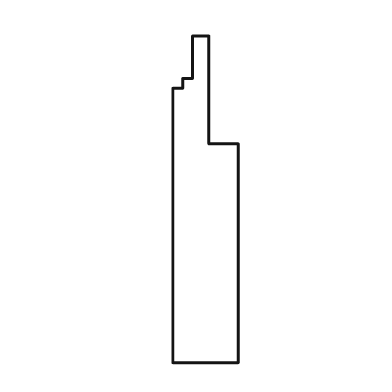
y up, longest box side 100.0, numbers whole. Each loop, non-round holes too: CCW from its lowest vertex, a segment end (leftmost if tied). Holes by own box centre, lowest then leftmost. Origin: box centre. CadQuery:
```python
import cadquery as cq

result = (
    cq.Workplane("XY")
    .moveTo(-10.0, -50.0)
    .lineTo(10.0, -50.0)
    .lineTo(10.0, 17.0)
    .lineTo(1.0, 17.0)
    .lineTo(1.0, 50.0)
    .lineTo(-4.0, 50.0)
    .lineTo(-4.0, 37.0)
    .lineTo(-7.0, 37.0)
    .lineTo(-7.0, 34.0)
    .lineTo(-10.0, 34.0)
    .close()
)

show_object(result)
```